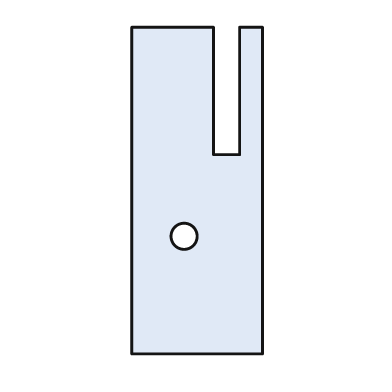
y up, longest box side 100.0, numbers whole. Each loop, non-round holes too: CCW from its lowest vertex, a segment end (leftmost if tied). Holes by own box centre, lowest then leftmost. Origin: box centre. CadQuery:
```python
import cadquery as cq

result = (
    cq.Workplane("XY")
    .moveTo(-20.0, -50.0)
    .lineTo(20.0, -50.0)
    .lineTo(20.0, 50.0)
    .lineTo(13.0, 50.0)
    .lineTo(13.0, 11.0)
    .lineTo(5.0, 11.0)
    .lineTo(5.0, 50.0)
    .lineTo(-20.0, 50.0)
    .close()
    .moveTo(-4.0, -14.0)
    .circle(4.0)
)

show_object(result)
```